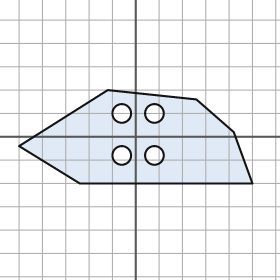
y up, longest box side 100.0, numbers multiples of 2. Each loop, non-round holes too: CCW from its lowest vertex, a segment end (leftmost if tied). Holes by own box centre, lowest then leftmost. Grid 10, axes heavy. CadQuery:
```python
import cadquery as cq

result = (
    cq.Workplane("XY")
    .moveTo(-24.0, -20.0)
    .lineTo(50.0, -20.0)
    .lineTo(42.0, 2.0)
    .lineTo(26.0, 16.0)
    .lineTo(-12.0, 20.0)
    .lineTo(-50.0, -4.0)
    .close()
    .moveTo(-6.0, -8.0)
    .circle(4.0)
    .moveTo(8.0, -8.0)
    .circle(4.0)
    .moveTo(-6.0, 10.0)
    .circle(4.0)
    .moveTo(8.0, 10.0)
    .circle(4.0)
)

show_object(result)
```